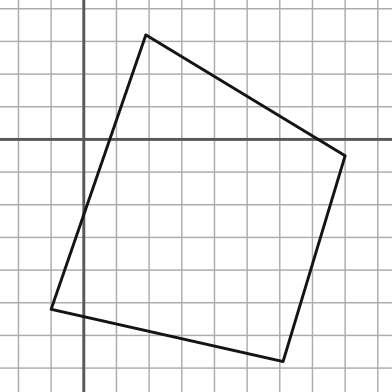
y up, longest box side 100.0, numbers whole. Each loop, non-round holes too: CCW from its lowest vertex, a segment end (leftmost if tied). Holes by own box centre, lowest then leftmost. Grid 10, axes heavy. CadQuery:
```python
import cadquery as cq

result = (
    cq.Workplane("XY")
    .moveTo(61.0, -68.0)
    .lineTo(80.0, -5.0)
    .lineTo(19.0, 32.0)
    .lineTo(-10.0, -52.0)
    .close()
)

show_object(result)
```